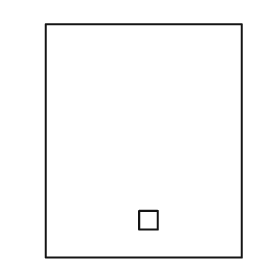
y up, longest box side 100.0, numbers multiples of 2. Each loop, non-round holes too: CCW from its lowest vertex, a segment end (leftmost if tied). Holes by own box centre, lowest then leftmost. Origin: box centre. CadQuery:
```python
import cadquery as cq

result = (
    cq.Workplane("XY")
    .moveTo(-42.0, -50.0)
    .lineTo(42.0, -50.0)
    .lineTo(42.0, 50.0)
    .lineTo(-42.0, 50.0)
    .close()
    .moveTo(-2.0, -38.0)
    .lineTo(6.0, -38.0)
    .lineTo(6.0, -30.0)
    .lineTo(-2.0, -30.0)
    .close()
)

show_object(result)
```